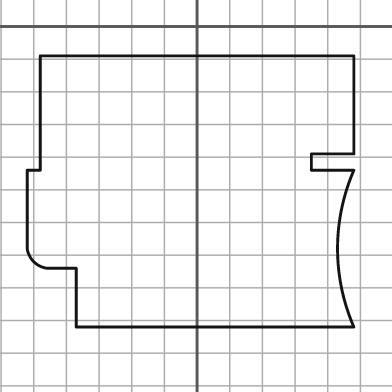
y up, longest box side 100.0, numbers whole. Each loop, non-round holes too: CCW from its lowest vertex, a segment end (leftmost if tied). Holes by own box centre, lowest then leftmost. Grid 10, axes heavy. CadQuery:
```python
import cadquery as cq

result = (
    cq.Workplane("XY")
    .moveTo(-37.0, -92.0)
    .lineTo(48.0, -92.0)
    .threePointArc((43.0, -68.0), (48.0, -44.0))
    .lineTo(35.0, -44.0)
    .lineTo(35.0, -39.0)
    .lineTo(48.0, -39.0)
    .lineTo(48.0, -9.0)
    .lineTo(-48.0, -9.0)
    .lineTo(-48.0, -44.0)
    .lineTo(-52.0, -44.0)
    .lineTo(-52.0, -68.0)
    .threePointArc((-50.0, -72.0), (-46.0, -74.0))
    .lineTo(-37.0, -74.0)
    .close()
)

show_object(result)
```